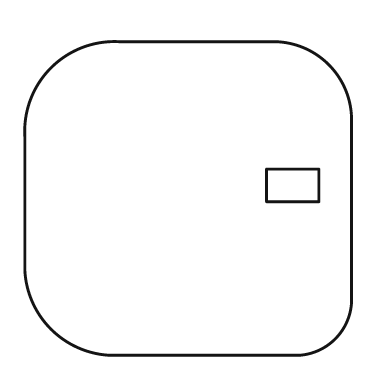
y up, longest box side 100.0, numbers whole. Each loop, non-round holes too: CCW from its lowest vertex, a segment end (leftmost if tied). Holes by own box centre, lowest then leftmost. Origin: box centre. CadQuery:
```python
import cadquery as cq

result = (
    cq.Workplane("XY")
    .moveTo(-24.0, -48.0)
    .lineTo(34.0, -48.0)
    .threePointArc((45.0, -43.0), (50.0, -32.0))
    .lineTo(50.0, 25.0)
    .threePointArc((43.0, 41.0), (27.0, 48.0))
    .lineTo(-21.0, 48.0)
    .threePointArc((-42.0, 40.0), (-50.0, 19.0))
    .lineTo(-50.0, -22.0)
    .threePointArc((-42.0, -40.0), (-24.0, -48.0))
    .close()
    .moveTo(24.0, -1.0)
    .lineTo(40.0, -1.0)
    .lineTo(40.0, 9.0)
    .lineTo(24.0, 9.0)
    .close()
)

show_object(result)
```